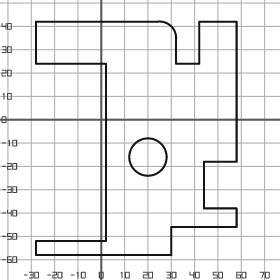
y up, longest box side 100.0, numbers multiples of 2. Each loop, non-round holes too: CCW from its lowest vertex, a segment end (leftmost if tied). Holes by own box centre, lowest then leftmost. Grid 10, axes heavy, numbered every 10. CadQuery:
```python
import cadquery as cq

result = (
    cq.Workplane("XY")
    .moveTo(-28.0, -58.0)
    .lineTo(30.0, -58.0)
    .lineTo(30.0, -46.0)
    .lineTo(58.0, -46.0)
    .lineTo(58.0, -38.0)
    .lineTo(44.0, -38.0)
    .lineTo(44.0, -18.0)
    .lineTo(58.0, -18.0)
    .lineTo(58.0, 42.0)
    .lineTo(42.0, 42.0)
    .lineTo(42.0, 24.0)
    .lineTo(32.0, 24.0)
    .lineTo(32.0, 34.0)
    .threePointArc((30.0, 40.0), (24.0, 42.0))
    .lineTo(-28.0, 42.0)
    .lineTo(-28.0, 24.0)
    .lineTo(2.0, 24.0)
    .lineTo(2.0, -52.0)
    .lineTo(-28.0, -52.0)
    .close()
    .moveTo(20.0, -16.0)
    .circle(8.0)
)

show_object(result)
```